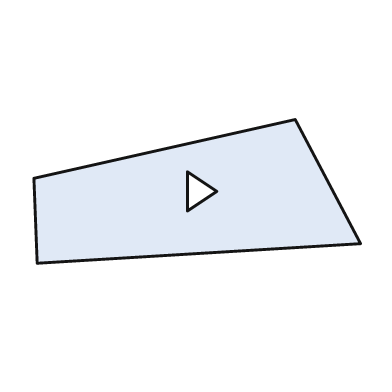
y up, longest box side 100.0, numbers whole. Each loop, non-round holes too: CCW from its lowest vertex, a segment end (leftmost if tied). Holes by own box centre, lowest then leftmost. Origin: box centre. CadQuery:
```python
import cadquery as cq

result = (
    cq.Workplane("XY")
    .moveTo(-49.0, -22.0)
    .lineTo(50.0, -16.0)
    .lineTo(30.0, 22.0)
    .lineTo(-50.0, 4.0)
    .close()
    .moveTo(-3.0, -6.0)
    .lineTo(6.0, 0.0)
    .lineTo(-3.0, 6.0)
    .close()
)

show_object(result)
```